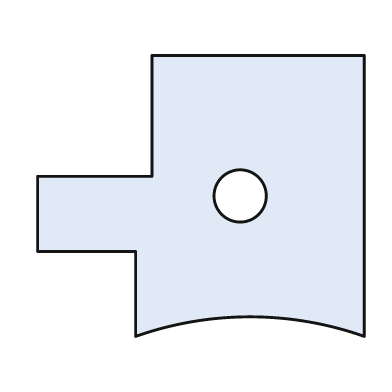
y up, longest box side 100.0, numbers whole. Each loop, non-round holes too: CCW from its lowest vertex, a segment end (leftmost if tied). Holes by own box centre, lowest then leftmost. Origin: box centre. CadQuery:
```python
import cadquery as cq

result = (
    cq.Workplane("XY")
    .moveTo(-20.0, -43.0)
    .threePointArc((15.0, -37.0), (50.0, -43.0))
    .lineTo(50.0, 43.0)
    .lineTo(-15.0, 43.0)
    .lineTo(-15.0, 6.0)
    .lineTo(-50.0, 6.0)
    .lineTo(-50.0, -17.0)
    .lineTo(-20.0, -17.0)
    .close()
    .moveTo(12.0, 0.0)
    .circle(8.0)
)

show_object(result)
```